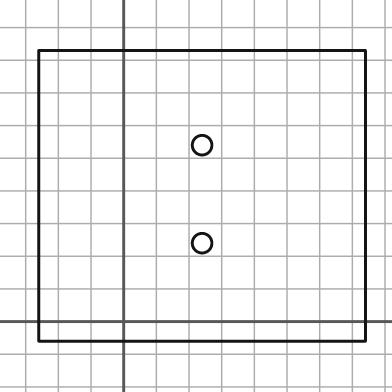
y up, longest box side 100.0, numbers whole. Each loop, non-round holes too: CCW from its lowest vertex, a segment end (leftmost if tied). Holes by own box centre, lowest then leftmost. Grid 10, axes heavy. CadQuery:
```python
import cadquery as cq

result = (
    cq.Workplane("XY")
    .moveTo(-26.0, -6.0)
    .lineTo(74.0, -6.0)
    .lineTo(74.0, 83.0)
    .lineTo(-26.0, 83.0)
    .close()
    .moveTo(24.0, 24.0)
    .circle(3.0)
    .moveTo(24.0, 54.0)
    .circle(3.0)
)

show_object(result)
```